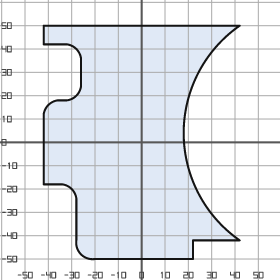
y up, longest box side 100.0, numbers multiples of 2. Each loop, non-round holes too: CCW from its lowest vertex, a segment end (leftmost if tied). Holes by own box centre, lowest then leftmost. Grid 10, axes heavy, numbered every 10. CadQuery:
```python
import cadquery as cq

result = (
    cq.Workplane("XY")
    .moveTo(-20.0, -50.0)
    .lineTo(22.0, -50.0)
    .lineTo(22.0, -42.0)
    .lineTo(42.0, -42.0)
    .threePointArc((18.0, 4.0), (42.0, 50.0))
    .lineTo(-42.0, 50.0)
    .lineTo(-42.0, 42.0)
    .lineTo(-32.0, 42.0)
    .threePointArc((-28.0, 40.0), (-26.0, 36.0))
    .lineTo(-26.0, 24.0)
    .threePointArc((-28.0, 20.0), (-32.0, 18.0))
    .lineTo(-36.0, 18.0)
    .threePointArc((-40.0, 16.0), (-42.0, 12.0))
    .lineTo(-42.0, -18.0)
    .lineTo(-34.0, -18.0)
    .threePointArc((-30.0, -20.0), (-28.0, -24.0))
    .lineTo(-28.0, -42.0)
    .threePointArc((-26.0, -48.0), (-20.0, -50.0))
    .close()
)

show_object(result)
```